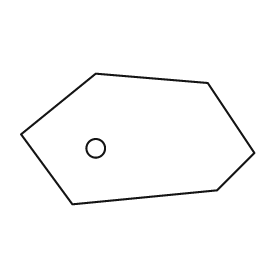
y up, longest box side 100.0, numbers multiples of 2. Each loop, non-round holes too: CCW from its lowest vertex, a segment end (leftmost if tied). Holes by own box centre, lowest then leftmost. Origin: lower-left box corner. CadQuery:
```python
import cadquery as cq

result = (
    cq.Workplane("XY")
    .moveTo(22.0, 0.0)
    .lineTo(84.0, 6.0)
    .lineTo(100.0, 22.0)
    .lineTo(80.0, 52.0)
    .lineTo(32.0, 56.0)
    .lineTo(0.0, 30.0)
    .close()
    .moveTo(32.0, 24.0)
    .circle(4.0)
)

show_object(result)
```